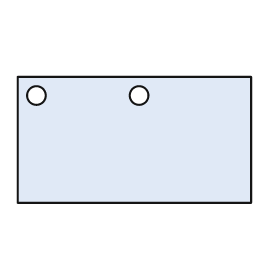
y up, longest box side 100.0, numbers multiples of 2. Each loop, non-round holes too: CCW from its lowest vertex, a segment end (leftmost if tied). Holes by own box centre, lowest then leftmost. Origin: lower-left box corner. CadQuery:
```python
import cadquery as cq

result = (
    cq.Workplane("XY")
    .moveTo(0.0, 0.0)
    .lineTo(100.0, 0.0)
    .lineTo(100.0, 54.0)
    .lineTo(0.0, 54.0)
    .close()
    .moveTo(8.0, 46.0)
    .circle(4.0)
    .moveTo(52.0, 46.0)
    .circle(4.0)
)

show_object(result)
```